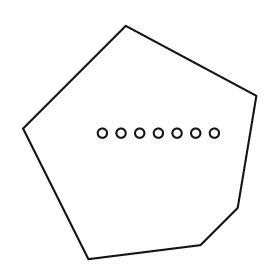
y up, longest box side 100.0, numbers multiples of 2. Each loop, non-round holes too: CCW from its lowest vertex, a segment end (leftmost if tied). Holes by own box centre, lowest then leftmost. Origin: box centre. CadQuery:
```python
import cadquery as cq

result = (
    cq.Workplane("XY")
    .moveTo(-22.0, -50.0)
    .lineTo(26.0, -44.0)
    .lineTo(42.0, -28.0)
    .lineTo(50.0, 20.0)
    .lineTo(-6.0, 50.0)
    .lineTo(-50.0, 6.0)
    .close()
    .moveTo(-16.0, 4.0)
    .circle(2.0)
    .moveTo(-8.0, 4.0)
    .circle(2.0)
    .moveTo(0.0, 4.0)
    .circle(2.0)
    .moveTo(8.0, 4.0)
    .circle(2.0)
    .moveTo(16.0, 4.0)
    .circle(2.0)
    .moveTo(24.0, 4.0)
    .circle(2.0)
    .moveTo(32.0, 4.0)
    .circle(2.0)
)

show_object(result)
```